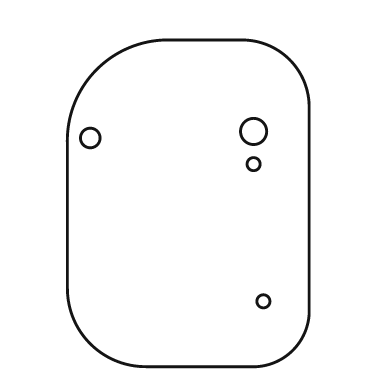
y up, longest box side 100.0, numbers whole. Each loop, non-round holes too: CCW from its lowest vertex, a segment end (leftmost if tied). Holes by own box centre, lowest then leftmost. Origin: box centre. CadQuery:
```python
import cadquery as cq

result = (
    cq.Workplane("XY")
    .moveTo(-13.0, -50.0)
    .lineTo(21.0, -50.0)
    .threePointArc((32.0, -45.0), (37.0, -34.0))
    .lineTo(37.0, 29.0)
    .threePointArc((31.0, 44.0), (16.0, 50.0))
    .lineTo(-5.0, 50.0)
    .threePointArc((-28.0, 41.0), (-37.0, 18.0))
    .lineTo(-37.0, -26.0)
    .threePointArc((-30.0, -43.0), (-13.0, -50.0))
    .close()
    .moveTo(23.0, -30.0)
    .circle(2.0)
    .moveTo(20.0, 12.0)
    .circle(2.0)
    .moveTo(-30.0, 20.0)
    .circle(3.0)
    .moveTo(20.0, 22.0)
    .circle(4.0)
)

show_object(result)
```